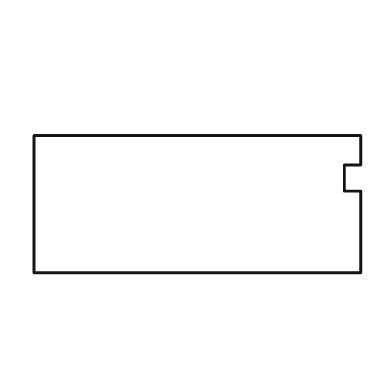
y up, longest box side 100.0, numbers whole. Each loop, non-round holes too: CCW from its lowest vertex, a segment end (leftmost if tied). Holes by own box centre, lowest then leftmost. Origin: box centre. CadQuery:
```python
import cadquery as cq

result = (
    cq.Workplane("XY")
    .moveTo(-50.0, -21.0)
    .lineTo(50.0, -21.0)
    .lineTo(50.0, 4.0)
    .lineTo(45.0, 4.0)
    .lineTo(45.0, 12.0)
    .lineTo(50.0, 12.0)
    .lineTo(50.0, 21.0)
    .lineTo(-50.0, 21.0)
    .close()
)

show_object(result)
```